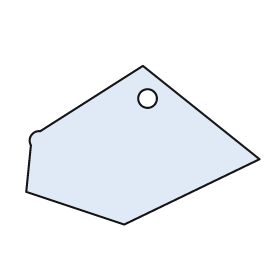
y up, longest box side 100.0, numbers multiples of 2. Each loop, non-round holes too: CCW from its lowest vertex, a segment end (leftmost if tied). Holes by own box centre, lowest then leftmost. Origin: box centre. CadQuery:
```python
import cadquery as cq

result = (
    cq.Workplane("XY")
    .moveTo(-8.0, -34.0)
    .lineTo(50.0, -6.0)
    .lineTo(0.0, 34.0)
    .lineTo(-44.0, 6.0)
    .threePointArc((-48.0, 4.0), (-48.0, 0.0))
    .lineTo(-50.0, -20.0)
    .close()
    .moveTo(2.0, 20.0)
    .circle(4.0)
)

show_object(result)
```